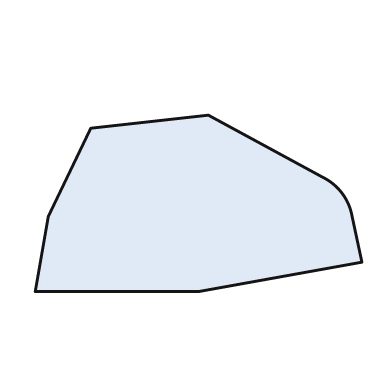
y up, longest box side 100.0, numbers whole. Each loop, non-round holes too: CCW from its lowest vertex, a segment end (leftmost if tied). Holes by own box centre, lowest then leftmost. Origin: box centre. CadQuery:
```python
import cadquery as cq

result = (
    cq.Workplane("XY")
    .moveTo(-50.0, -27.0)
    .lineTo(0.0, -27.0)
    .lineTo(50.0, -18.0)
    .lineTo(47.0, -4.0)
    .threePointArc((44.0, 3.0), (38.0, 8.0))
    .lineTo(3.0, 27.0)
    .lineTo(-33.0, 23.0)
    .lineTo(-46.0, -4.0)
    .close()
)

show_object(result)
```